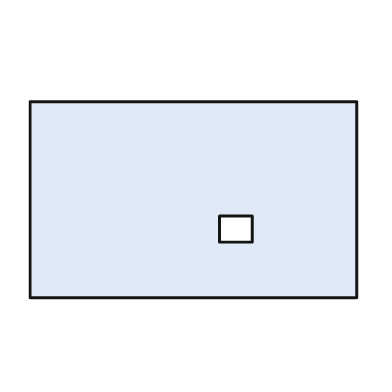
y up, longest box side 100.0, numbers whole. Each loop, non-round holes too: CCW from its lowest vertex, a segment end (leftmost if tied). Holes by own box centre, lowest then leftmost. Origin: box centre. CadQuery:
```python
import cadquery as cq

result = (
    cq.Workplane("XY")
    .moveTo(-50.0, -30.0)
    .lineTo(50.0, -30.0)
    .lineTo(50.0, 30.0)
    .lineTo(-50.0, 30.0)
    .close()
    .moveTo(8.0, -13.0)
    .lineTo(18.0, -13.0)
    .lineTo(18.0, -5.0)
    .lineTo(8.0, -5.0)
    .close()
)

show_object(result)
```